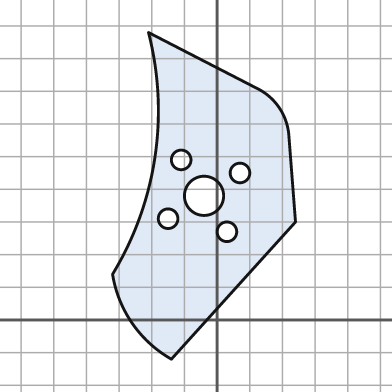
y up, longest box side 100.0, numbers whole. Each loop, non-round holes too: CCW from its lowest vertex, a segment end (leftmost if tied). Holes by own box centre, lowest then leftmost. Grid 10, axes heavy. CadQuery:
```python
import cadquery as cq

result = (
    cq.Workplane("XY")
    .moveTo(-14.0, -12.0)
    .lineTo(24.0, 30.0)
    .lineTo(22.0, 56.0)
    .threePointArc((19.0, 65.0), (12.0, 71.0))
    .lineTo(-21.0, 88.0)
    .threePointArc((-19.0, 50.0), (-32.0, 14.0))
    .threePointArc((-26.0, -1.0), (-14.0, -12.0))
    .close()
    .moveTo(3.0, 27.0)
    .circle(3.0)
    .moveTo(-15.0, 31.0)
    .circle(3.0)
    .moveTo(-4.0, 38.0)
    .circle(6.0)
    .moveTo(7.0, 45.0)
    .circle(3.0)
    .moveTo(-11.0, 49.0)
    .circle(3.0)
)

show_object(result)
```